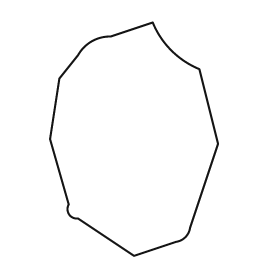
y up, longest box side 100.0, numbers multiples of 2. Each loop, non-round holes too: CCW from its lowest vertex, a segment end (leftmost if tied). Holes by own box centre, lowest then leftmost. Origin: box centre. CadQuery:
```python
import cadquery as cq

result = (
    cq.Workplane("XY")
    .moveTo(0.0, -50.0)
    .lineTo(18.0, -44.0)
    .threePointArc((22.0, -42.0), (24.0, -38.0))
    .lineTo(36.0, -2.0)
    .lineTo(28.0, 30.0)
    .threePointArc((16.0, 38.0), (8.0, 50.0))
    .lineTo(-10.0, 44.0)
    .threePointArc((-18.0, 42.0), (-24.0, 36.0))
    .lineTo(-32.0, 26.0)
    .lineTo(-36.0, 0.0)
    .lineTo(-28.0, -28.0)
    .threePointArc((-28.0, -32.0), (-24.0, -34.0))
    .close()
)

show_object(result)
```